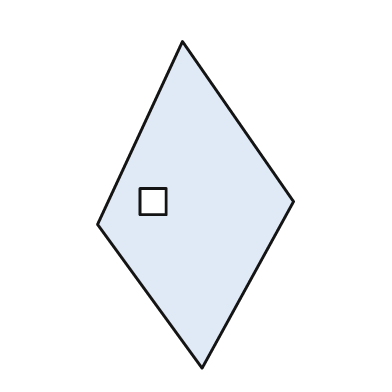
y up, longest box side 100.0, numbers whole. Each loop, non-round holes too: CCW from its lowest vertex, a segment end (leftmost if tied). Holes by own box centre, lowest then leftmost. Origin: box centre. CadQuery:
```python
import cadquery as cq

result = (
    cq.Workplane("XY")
    .moveTo(2.0, -50.0)
    .lineTo(30.0, 1.0)
    .lineTo(-4.0, 50.0)
    .lineTo(-30.0, -6.0)
    .close()
    .moveTo(-17.0, -3.0)
    .lineTo(-9.0, -3.0)
    .lineTo(-9.0, 5.0)
    .lineTo(-17.0, 5.0)
    .close()
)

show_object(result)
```